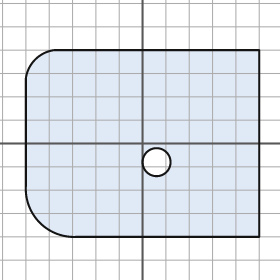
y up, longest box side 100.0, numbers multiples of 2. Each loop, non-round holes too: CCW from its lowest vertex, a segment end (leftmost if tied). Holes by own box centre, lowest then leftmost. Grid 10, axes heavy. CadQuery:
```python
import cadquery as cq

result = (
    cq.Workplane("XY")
    .moveTo(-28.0, -40.0)
    .lineTo(50.0, -40.0)
    .lineTo(50.0, 40.0)
    .lineTo(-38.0, 40.0)
    .threePointArc((-46.0, 36.0), (-50.0, 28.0))
    .lineTo(-50.0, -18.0)
    .threePointArc((-44.0, -34.0), (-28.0, -40.0))
    .close()
    .moveTo(6.0, -8.0)
    .circle(6.0)
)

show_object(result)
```